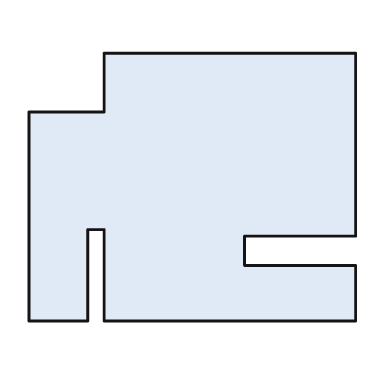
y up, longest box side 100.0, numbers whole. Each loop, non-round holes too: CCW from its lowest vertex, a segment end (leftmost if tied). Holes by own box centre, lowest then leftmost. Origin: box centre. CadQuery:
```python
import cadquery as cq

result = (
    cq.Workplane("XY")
    .moveTo(-50.0, -41.0)
    .lineTo(-32.0, -41.0)
    .lineTo(-32.0, -13.0)
    .lineTo(-27.0, -13.0)
    .lineTo(-27.0, -41.0)
    .lineTo(50.0, -41.0)
    .lineTo(50.0, -24.0)
    .lineTo(16.0, -24.0)
    .lineTo(16.0, -15.0)
    .lineTo(50.0, -15.0)
    .lineTo(50.0, 41.0)
    .lineTo(-27.0, 41.0)
    .lineTo(-27.0, 23.0)
    .lineTo(-50.0, 23.0)
    .close()
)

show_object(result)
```